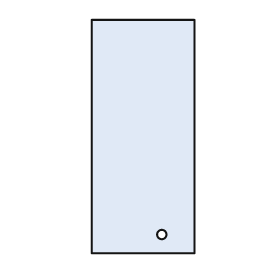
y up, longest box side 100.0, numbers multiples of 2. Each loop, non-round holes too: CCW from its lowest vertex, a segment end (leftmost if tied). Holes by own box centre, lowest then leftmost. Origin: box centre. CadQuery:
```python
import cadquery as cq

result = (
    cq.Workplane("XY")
    .moveTo(-22.0, -50.0)
    .lineTo(22.0, -50.0)
    .lineTo(22.0, 50.0)
    .lineTo(-22.0, 50.0)
    .close()
    .moveTo(8.0, -42.0)
    .circle(2.0)
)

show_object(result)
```